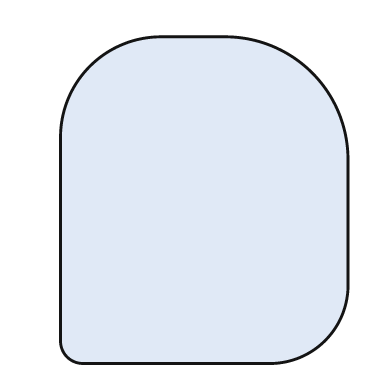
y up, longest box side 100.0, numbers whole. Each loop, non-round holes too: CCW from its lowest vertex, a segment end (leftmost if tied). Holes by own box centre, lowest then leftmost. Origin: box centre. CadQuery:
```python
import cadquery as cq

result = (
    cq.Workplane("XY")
    .moveTo(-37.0, -50.0)
    .lineTo(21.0, -50.0)
    .threePointArc((37.0, -43.0), (44.0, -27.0))
    .lineTo(44.0, 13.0)
    .threePointArc((33.0, 39.0), (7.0, 50.0))
    .lineTo(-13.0, 50.0)
    .threePointArc((-35.0, 41.0), (-44.0, 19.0))
    .lineTo(-44.0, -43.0)
    .threePointArc((-42.0, -48.0), (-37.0, -50.0))
    .close()
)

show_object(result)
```